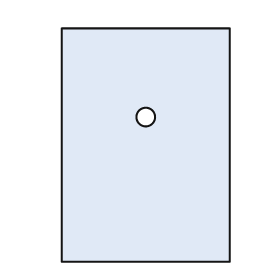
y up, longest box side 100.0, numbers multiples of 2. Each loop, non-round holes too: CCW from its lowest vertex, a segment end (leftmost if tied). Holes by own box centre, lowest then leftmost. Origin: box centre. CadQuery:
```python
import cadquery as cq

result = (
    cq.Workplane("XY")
    .moveTo(-36.0, -50.0)
    .lineTo(36.0, -50.0)
    .lineTo(36.0, 50.0)
    .lineTo(-36.0, 50.0)
    .close()
    .moveTo(0.0, 12.0)
    .circle(4.0)
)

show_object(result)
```